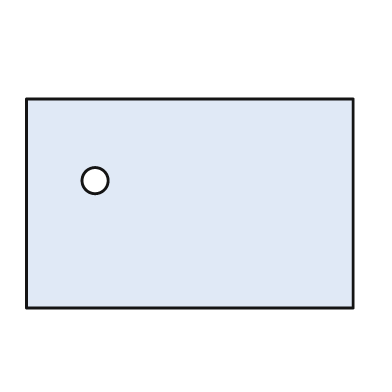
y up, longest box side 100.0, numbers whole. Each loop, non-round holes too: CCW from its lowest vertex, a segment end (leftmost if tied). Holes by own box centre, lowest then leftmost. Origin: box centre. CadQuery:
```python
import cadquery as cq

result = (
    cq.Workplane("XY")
    .moveTo(-50.0, -32.0)
    .lineTo(50.0, -32.0)
    .lineTo(50.0, 32.0)
    .lineTo(-50.0, 32.0)
    .close()
    .moveTo(-29.0, 7.0)
    .circle(4.0)
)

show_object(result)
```